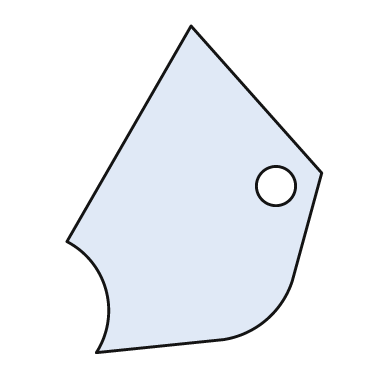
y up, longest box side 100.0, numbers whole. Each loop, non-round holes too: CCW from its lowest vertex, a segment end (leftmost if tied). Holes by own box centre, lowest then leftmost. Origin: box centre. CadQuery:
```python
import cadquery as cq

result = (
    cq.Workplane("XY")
    .moveTo(-30.0, -50.0)
    .lineTo(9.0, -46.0)
    .threePointArc((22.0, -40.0), (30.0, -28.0))
    .lineTo(39.0, 5.0)
    .lineTo(-1.0, 50.0)
    .lineTo(-39.0, -16.0)
    .threePointArc((-27.0, -31.0), (-30.0, -50.0))
    .close()
    .moveTo(25.0, 1.0)
    .circle(6.0)
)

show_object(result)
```